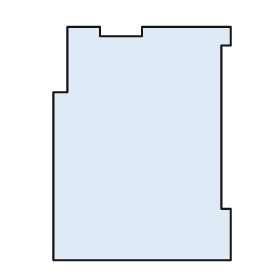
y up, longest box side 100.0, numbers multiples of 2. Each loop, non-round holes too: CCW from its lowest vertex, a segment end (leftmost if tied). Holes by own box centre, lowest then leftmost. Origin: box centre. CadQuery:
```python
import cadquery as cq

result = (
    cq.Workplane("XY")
    .moveTo(-38.0, -50.0)
    .lineTo(38.0, -50.0)
    .lineTo(38.0, -28.0)
    .lineTo(34.0, -28.0)
    .lineTo(34.0, 42.0)
    .lineTo(38.0, 42.0)
    .lineTo(38.0, 50.0)
    .lineTo(0.0, 50.0)
    .lineTo(0.0, 46.0)
    .lineTo(-18.0, 46.0)
    .lineTo(-18.0, 50.0)
    .lineTo(-32.0, 50.0)
    .lineTo(-32.0, 22.0)
    .lineTo(-38.0, 22.0)
    .close()
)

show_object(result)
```